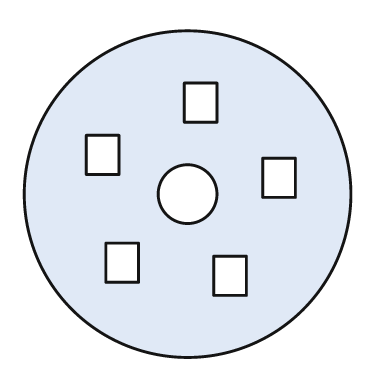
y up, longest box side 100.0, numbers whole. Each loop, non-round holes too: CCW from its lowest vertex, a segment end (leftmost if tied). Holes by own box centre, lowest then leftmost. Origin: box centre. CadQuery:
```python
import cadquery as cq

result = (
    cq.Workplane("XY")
    .moveTo(0.0, 0.0)
    .circle(50.0)
    .moveTo(8.0, -31.0)
    .lineTo(18.0, -31.0)
    .lineTo(18.0, -19.0)
    .lineTo(8.0, -19.0)
    .close()
    .moveTo(-25.0, -27.0)
    .lineTo(-15.0, -27.0)
    .lineTo(-15.0, -15.0)
    .lineTo(-25.0, -15.0)
    .close()
    .moveTo(0.0, 0.0)
    .circle(9.0)
    .moveTo(23.0, -1.0)
    .lineTo(33.0, -1.0)
    .lineTo(33.0, 11.0)
    .lineTo(23.0, 11.0)
    .close()
    .moveTo(-31.0, 6.0)
    .lineTo(-21.0, 6.0)
    .lineTo(-21.0, 18.0)
    .lineTo(-31.0, 18.0)
    .close()
    .moveTo(-1.0, 22.0)
    .lineTo(9.0, 22.0)
    .lineTo(9.0, 34.0)
    .lineTo(-1.0, 34.0)
    .close()
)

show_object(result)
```